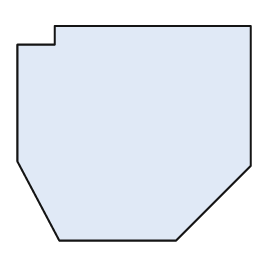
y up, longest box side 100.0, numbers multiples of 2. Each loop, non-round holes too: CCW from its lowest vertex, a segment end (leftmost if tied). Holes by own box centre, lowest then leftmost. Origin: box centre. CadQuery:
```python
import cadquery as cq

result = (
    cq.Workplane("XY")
    .moveTo(-32.0, -46.0)
    .lineTo(18.0, -46.0)
    .lineTo(50.0, -14.0)
    .lineTo(50.0, 46.0)
    .lineTo(-34.0, 46.0)
    .lineTo(-34.0, 38.0)
    .lineTo(-50.0, 38.0)
    .lineTo(-50.0, -12.0)
    .close()
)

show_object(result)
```